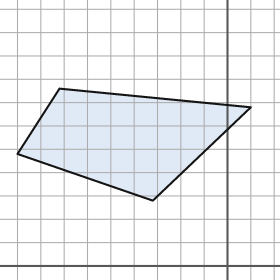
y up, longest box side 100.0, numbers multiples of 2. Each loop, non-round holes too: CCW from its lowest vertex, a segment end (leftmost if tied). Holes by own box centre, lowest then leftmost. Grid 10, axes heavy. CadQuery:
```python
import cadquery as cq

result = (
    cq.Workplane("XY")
    .moveTo(-32.0, 28.0)
    .lineTo(10.0, 68.0)
    .lineTo(-72.0, 76.0)
    .lineTo(-90.0, 48.0)
    .close()
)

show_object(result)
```